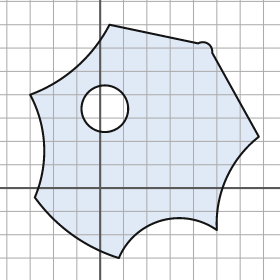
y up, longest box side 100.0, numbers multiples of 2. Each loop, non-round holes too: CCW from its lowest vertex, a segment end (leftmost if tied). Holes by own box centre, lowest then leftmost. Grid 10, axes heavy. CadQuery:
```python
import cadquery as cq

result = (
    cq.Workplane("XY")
    .moveTo(8.0, -30.0)
    .threePointArc((26.0, -14.0), (50.0, -18.0))
    .threePointArc((54.0, 4.0), (68.0, 22.0))
    .lineTo(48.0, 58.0)
    .threePointArc((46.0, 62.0), (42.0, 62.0))
    .lineTo(4.0, 70.0)
    .threePointArc((-10.0, 52.0), (-30.0, 40.0))
    .threePointArc((-24.0, 18.0), (-28.0, -4.0))
    .threePointArc((-12.0, -20.0), (8.0, -30.0))
    .close()
    .moveTo(2.0, 34.0)
    .circle(10.0)
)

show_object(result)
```